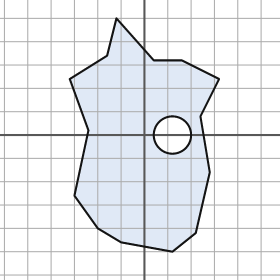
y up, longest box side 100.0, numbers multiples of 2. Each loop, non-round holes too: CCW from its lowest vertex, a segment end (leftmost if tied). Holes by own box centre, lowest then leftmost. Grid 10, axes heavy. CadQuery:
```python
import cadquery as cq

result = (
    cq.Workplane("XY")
    .moveTo(12.0, -50.0)
    .lineTo(22.0, -42.0)
    .lineTo(28.0, -16.0)
    .lineTo(24.0, 8.0)
    .lineTo(32.0, 24.0)
    .lineTo(16.0, 32.0)
    .lineTo(4.0, 32.0)
    .lineTo(-12.0, 50.0)
    .lineTo(-16.0, 34.0)
    .lineTo(-32.0, 24.0)
    .lineTo(-24.0, 2.0)
    .lineTo(-30.0, -26.0)
    .lineTo(-20.0, -40.0)
    .lineTo(-10.0, -46.0)
    .close()
    .moveTo(12.0, 0.0)
    .circle(8.0)
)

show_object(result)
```